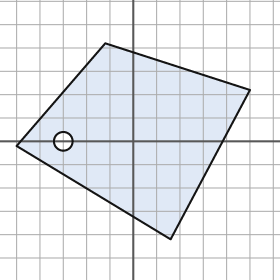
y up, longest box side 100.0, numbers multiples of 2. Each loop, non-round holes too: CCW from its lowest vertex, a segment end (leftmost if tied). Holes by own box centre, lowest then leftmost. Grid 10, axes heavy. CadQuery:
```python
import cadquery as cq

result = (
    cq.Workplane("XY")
    .moveTo(16.0, -42.0)
    .lineTo(50.0, 22.0)
    .lineTo(-12.0, 42.0)
    .lineTo(-50.0, -2.0)
    .close()
    .moveTo(-30.0, 0.0)
    .circle(4.0)
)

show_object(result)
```